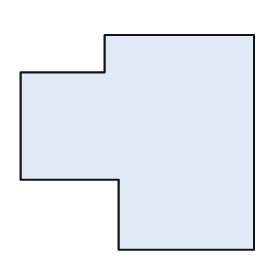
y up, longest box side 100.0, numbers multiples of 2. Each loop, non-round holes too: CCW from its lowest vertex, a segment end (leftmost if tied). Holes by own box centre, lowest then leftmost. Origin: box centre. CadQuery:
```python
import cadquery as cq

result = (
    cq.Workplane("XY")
    .moveTo(-8.0, -46.0)
    .lineTo(50.0, -46.0)
    .lineTo(50.0, 46.0)
    .lineTo(-14.0, 46.0)
    .lineTo(-14.0, 30.0)
    .lineTo(-50.0, 30.0)
    .lineTo(-50.0, -16.0)
    .lineTo(-8.0, -16.0)
    .close()
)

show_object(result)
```